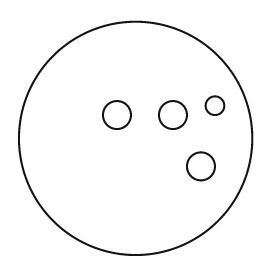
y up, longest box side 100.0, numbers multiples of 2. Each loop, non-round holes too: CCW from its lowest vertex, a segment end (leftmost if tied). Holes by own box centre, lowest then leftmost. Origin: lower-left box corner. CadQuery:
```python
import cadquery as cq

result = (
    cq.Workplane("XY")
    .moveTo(50.0, 50.0)
    .circle(50.0)
    .moveTo(78.0, 38.0)
    .circle(6.0)
    .moveTo(42.0, 60.0)
    .circle(6.0)
    .moveTo(66.0, 60.0)
    .circle(6.0)
    .moveTo(84.0, 64.0)
    .circle(4.0)
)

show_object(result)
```